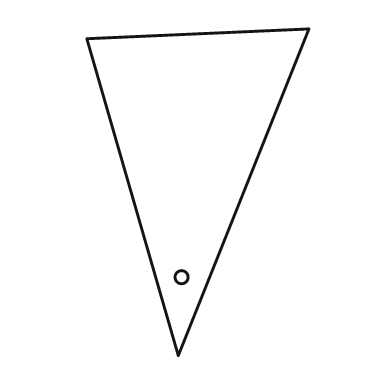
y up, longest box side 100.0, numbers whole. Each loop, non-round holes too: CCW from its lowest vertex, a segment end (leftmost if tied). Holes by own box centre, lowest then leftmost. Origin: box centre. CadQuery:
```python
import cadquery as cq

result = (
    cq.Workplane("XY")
    .moveTo(-6.0, -50.0)
    .lineTo(34.0, 50.0)
    .lineTo(-34.0, 47.0)
    .close()
    .moveTo(-5.0, -26.0)
    .circle(2.0)
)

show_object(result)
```